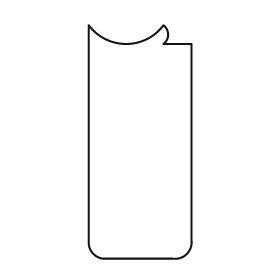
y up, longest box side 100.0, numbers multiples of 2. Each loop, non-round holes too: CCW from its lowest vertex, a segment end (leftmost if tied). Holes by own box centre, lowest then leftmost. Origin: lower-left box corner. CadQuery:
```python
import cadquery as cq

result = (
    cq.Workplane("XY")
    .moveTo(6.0, 0.0)
    .lineTo(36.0, 0.0)
    .threePointArc((42.0, 2.0), (44.0, 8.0))
    .lineTo(44.0, 92.0)
    .lineTo(32.0, 92.0)
    .threePointArc((34.0, 96.0), (32.0, 100.0))
    .threePointArc((16.0, 92.0), (0.0, 100.0))
    .lineTo(0.0, 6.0)
    .threePointArc((2.0, 2.0), (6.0, 0.0))
    .close()
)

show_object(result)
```